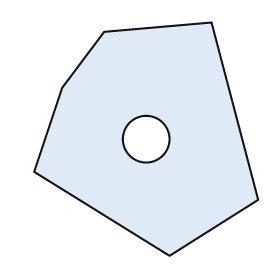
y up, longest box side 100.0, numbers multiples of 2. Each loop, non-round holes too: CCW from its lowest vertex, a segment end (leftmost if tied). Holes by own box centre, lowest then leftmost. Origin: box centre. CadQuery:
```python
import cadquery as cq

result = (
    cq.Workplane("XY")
    .moveTo(10.0, -50.0)
    .lineTo(48.0, -26.0)
    .lineTo(28.0, 50.0)
    .lineTo(-18.0, 46.0)
    .lineTo(-36.0, 22.0)
    .lineTo(-48.0, -14.0)
    .close()
    .moveTo(0.0, 0.0)
    .circle(10.0)
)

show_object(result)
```